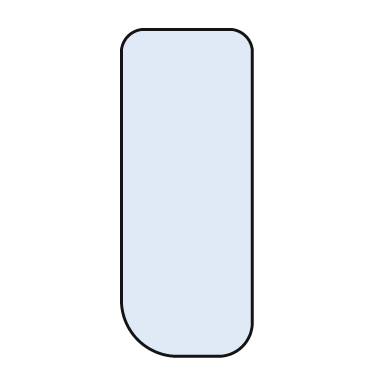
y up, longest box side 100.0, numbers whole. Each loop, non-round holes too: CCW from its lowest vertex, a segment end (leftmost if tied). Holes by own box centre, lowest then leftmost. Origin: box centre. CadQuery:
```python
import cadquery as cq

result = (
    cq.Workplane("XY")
    .moveTo(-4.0, -50.0)
    .lineTo(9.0, -50.0)
    .threePointArc((17.0, -47.0), (20.0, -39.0))
    .lineTo(20.0, 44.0)
    .threePointArc((18.0, 48.0), (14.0, 50.0))
    .lineTo(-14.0, 50.0)
    .threePointArc((-18.0, 48.0), (-20.0, 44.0))
    .lineTo(-20.0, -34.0)
    .threePointArc((-15.0, -45.0), (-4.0, -50.0))
    .close()
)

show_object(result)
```